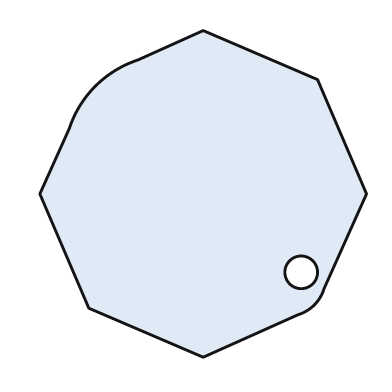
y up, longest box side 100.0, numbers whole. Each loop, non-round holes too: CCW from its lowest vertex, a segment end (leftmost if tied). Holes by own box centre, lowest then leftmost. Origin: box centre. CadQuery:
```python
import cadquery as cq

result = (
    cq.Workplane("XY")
    .moveTo(0.0, -50.0)
    .lineTo(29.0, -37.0)
    .threePointArc((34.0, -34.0), (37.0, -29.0))
    .lineTo(50.0, 0.0)
    .lineTo(35.0, 35.0)
    .lineTo(0.0, 50.0)
    .lineTo(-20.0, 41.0)
    .threePointArc((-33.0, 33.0), (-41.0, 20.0))
    .lineTo(-50.0, 0.0)
    .lineTo(-35.0, -35.0)
    .close()
    .moveTo(30.0, -24.0)
    .circle(5.0)
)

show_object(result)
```